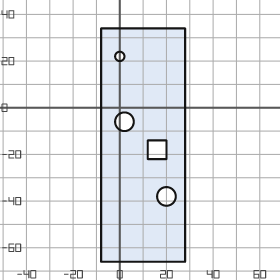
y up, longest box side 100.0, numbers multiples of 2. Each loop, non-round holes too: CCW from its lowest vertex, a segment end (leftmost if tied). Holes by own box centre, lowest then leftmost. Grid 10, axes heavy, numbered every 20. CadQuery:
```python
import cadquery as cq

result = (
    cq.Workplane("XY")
    .moveTo(-8.0, -66.0)
    .lineTo(28.0, -66.0)
    .lineTo(28.0, 34.0)
    .lineTo(-8.0, 34.0)
    .close()
    .moveTo(20.0, -38.0)
    .circle(4.0)
    .moveTo(12.0, -22.0)
    .lineTo(20.0, -22.0)
    .lineTo(20.0, -14.0)
    .lineTo(12.0, -14.0)
    .close()
    .moveTo(2.0, -6.0)
    .circle(4.0)
    .moveTo(0.0, 22.0)
    .circle(2.0)
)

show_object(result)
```